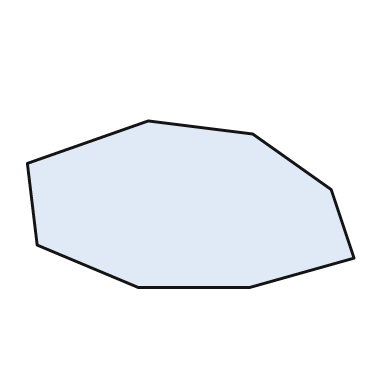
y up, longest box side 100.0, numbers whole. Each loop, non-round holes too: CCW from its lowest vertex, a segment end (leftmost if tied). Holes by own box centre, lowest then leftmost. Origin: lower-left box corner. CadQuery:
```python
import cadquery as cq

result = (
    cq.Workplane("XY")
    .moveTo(34.0, 0.0)
    .lineTo(68.0, 0.0)
    .lineTo(100.0, 9.0)
    .lineTo(93.0, 30.0)
    .lineTo(69.0, 47.0)
    .lineTo(37.0, 51.0)
    .lineTo(0.0, 38.0)
    .lineTo(3.0, 13.0)
    .close()
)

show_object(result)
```